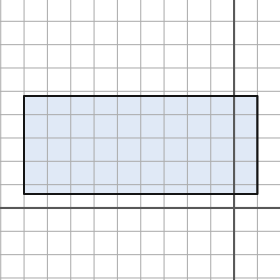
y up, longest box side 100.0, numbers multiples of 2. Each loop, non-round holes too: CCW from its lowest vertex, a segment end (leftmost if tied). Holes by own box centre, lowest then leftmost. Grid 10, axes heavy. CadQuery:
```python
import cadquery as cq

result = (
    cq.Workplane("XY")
    .moveTo(-90.0, 6.0)
    .lineTo(10.0, 6.0)
    .lineTo(10.0, 48.0)
    .lineTo(-90.0, 48.0)
    .close()
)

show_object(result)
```